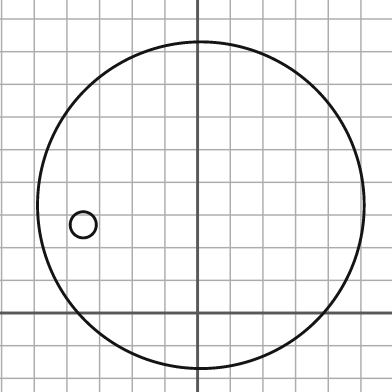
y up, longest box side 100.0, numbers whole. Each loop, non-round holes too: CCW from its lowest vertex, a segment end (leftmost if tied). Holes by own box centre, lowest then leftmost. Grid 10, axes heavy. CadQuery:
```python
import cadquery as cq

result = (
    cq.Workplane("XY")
    .moveTo(1.0, 33.0)
    .circle(50.0)
    .moveTo(-35.0, 27.0)
    .circle(4.0)
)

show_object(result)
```